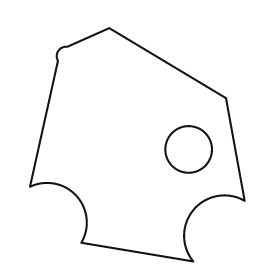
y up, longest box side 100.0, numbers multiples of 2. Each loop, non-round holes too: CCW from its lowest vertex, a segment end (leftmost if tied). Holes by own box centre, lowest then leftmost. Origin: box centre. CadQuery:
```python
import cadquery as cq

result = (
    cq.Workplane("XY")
    .moveTo(24.0, -50.0)
    .threePointArc((24.0, -28.0), (46.0, -24.0))
    .lineTo(38.0, 20.0)
    .lineTo(-12.0, 50.0)
    .lineTo(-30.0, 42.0)
    .threePointArc((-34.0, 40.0), (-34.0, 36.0))
    .lineTo(-46.0, -18.0)
    .threePointArc((-26.0, -22.0), (-24.0, -42.0))
    .close()
    .moveTo(22.0, -2.0)
    .circle(10.0)
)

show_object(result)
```